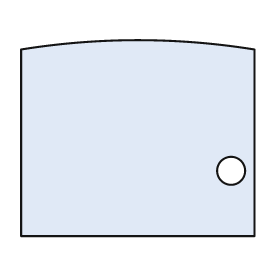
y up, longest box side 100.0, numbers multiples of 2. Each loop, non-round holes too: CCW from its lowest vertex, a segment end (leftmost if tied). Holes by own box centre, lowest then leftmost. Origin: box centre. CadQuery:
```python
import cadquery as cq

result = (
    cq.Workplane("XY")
    .moveTo(-50.0, -42.0)
    .lineTo(50.0, -42.0)
    .lineTo(50.0, 38.0)
    .threePointArc((0.0, 42.0), (-50.0, 38.0))
    .close()
    .moveTo(40.0, -14.0)
    .circle(6.0)
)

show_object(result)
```